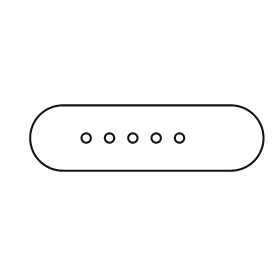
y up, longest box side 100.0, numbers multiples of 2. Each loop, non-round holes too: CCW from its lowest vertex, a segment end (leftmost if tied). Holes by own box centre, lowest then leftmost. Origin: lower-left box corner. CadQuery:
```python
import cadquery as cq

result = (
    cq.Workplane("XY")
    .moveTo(14.0, 0.0)
    .lineTo(86.0, 0.0)
    .threePointArc((100.0, 14.0), (86.0, 28.0))
    .lineTo(14.0, 28.0)
    .threePointArc((0.0, 14.0), (14.0, 0.0))
    .close()
    .moveTo(24.0, 14.0)
    .circle(2.0)
    .moveTo(34.0, 14.0)
    .circle(2.0)
    .moveTo(44.0, 14.0)
    .circle(2.0)
    .moveTo(54.0, 14.0)
    .circle(2.0)
    .moveTo(64.0, 14.0)
    .circle(2.0)
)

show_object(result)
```